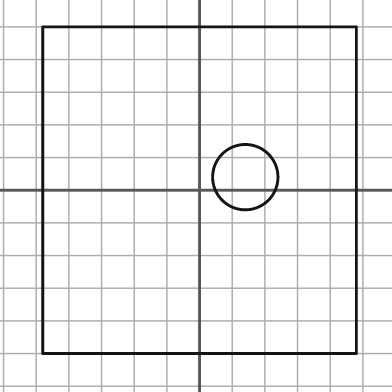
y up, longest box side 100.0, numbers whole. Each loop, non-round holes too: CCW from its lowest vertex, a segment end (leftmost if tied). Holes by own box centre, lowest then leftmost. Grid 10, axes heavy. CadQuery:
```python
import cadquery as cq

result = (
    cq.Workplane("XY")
    .moveTo(-48.0, -50.0)
    .lineTo(48.0, -50.0)
    .lineTo(48.0, 50.0)
    .lineTo(-48.0, 50.0)
    .close()
    .moveTo(14.0, 4.0)
    .circle(10.0)
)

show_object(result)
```